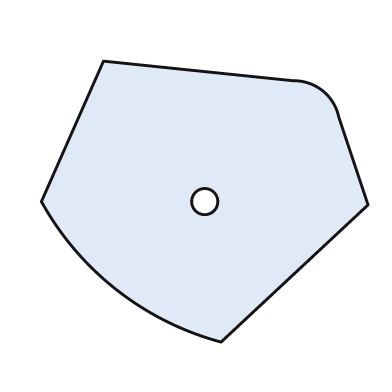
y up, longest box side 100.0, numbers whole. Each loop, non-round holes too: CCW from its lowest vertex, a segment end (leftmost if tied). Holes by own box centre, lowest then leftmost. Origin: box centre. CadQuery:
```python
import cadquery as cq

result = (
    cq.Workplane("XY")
    .moveTo(5.0, -43.0)
    .lineTo(50.0, -1.0)
    .lineTo(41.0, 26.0)
    .threePointArc((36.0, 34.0), (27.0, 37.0))
    .lineTo(-31.0, 43.0)
    .lineTo(-50.0, 0.0)
    .threePointArc((-27.0, -27.0), (5.0, -43.0))
    .close()
    .moveTo(0.0, 0.0)
    .circle(4.0)
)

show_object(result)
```